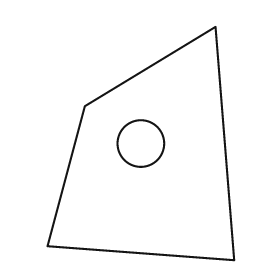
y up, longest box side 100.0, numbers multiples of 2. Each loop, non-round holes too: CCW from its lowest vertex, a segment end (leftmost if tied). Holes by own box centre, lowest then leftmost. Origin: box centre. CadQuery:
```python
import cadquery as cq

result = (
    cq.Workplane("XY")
    .moveTo(40.0, -50.0)
    .lineTo(32.0, 50.0)
    .lineTo(-24.0, 16.0)
    .lineTo(-40.0, -44.0)
    .close()
    .moveTo(0.0, 0.0)
    .circle(10.0)
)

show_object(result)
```